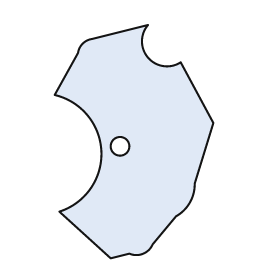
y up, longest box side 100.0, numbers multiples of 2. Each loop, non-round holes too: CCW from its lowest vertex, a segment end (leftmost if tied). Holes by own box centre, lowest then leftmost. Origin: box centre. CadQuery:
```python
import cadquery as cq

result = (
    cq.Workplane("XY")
    .moveTo(-10.0, -50.0)
    .lineTo(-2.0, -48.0)
    .threePointArc((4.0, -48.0), (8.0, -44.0))
    .lineTo(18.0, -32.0)
    .threePointArc((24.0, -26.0), (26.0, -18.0))
    .lineTo(34.0, 8.0)
    .lineTo(20.0, 34.0)
    .threePointArc((6.0, 36.0), (6.0, 50.0))
    .lineTo(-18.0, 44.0)
    .threePointArc((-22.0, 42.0), (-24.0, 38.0))
    .lineTo(-34.0, 20.0)
    .threePointArc((-14.0, -4.0), (-32.0, -30.0))
    .close()
    .moveTo(-6.0, -2.0)
    .circle(4.0)
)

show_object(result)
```